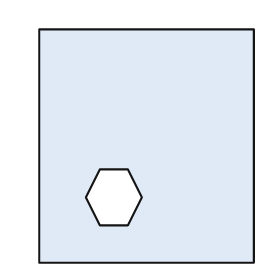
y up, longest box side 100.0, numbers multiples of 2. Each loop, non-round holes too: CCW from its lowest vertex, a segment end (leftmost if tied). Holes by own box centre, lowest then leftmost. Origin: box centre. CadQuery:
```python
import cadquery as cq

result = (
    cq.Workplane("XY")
    .moveTo(-46.0, -50.0)
    .lineTo(46.0, -50.0)
    .lineTo(46.0, 50.0)
    .lineTo(-46.0, 50.0)
    .close()
    .moveTo(-20.0, -34.0)
    .lineTo(-8.0, -34.0)
    .lineTo(-2.0, -22.0)
    .lineTo(-8.0, -10.0)
    .lineTo(-20.0, -10.0)
    .lineTo(-26.0, -22.0)
    .close()
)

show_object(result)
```